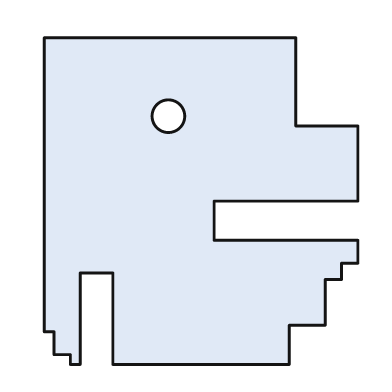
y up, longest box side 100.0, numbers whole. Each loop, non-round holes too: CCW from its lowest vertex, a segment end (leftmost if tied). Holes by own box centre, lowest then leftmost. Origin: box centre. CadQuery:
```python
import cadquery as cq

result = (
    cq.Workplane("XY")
    .moveTo(-40.0, -50.0)
    .lineTo(-37.0, -50.0)
    .lineTo(-37.0, -22.0)
    .lineTo(-27.0, -22.0)
    .lineTo(-27.0, -50.0)
    .lineTo(27.0, -50.0)
    .lineTo(27.0, -38.0)
    .lineTo(38.0, -38.0)
    .lineTo(38.0, -24.0)
    .lineTo(43.0, -24.0)
    .lineTo(43.0, -19.0)
    .lineTo(48.0, -19.0)
    .lineTo(48.0, -12.0)
    .lineTo(4.0, -12.0)
    .lineTo(4.0, 0.0)
    .lineTo(48.0, 0.0)
    .lineTo(48.0, 23.0)
    .lineTo(29.0, 23.0)
    .lineTo(29.0, 50.0)
    .lineTo(-48.0, 50.0)
    .lineTo(-48.0, -40.0)
    .lineTo(-45.0, -40.0)
    .lineTo(-45.0, -47.0)
    .lineTo(-40.0, -47.0)
    .close()
    .moveTo(-10.0, 26.0)
    .circle(5.0)
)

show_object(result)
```